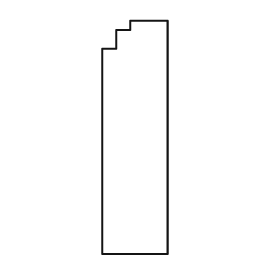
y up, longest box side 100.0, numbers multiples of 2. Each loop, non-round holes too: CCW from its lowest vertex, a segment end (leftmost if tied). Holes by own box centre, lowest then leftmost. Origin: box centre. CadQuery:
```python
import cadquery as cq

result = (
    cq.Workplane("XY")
    .moveTo(-14.0, -50.0)
    .lineTo(14.0, -50.0)
    .lineTo(14.0, 50.0)
    .lineTo(-2.0, 50.0)
    .lineTo(-2.0, 46.0)
    .lineTo(-8.0, 46.0)
    .lineTo(-8.0, 38.0)
    .lineTo(-14.0, 38.0)
    .close()
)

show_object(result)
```